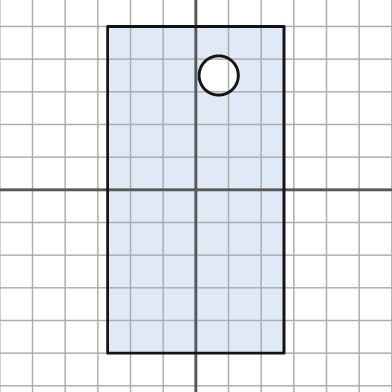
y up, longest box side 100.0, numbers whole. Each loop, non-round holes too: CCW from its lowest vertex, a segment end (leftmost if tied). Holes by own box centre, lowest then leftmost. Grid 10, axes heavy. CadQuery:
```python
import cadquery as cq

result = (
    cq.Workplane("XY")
    .moveTo(-27.0, -50.0)
    .lineTo(27.0, -50.0)
    .lineTo(27.0, 50.0)
    .lineTo(-27.0, 50.0)
    .close()
    .moveTo(7.0, 35.0)
    .circle(6.0)
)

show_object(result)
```